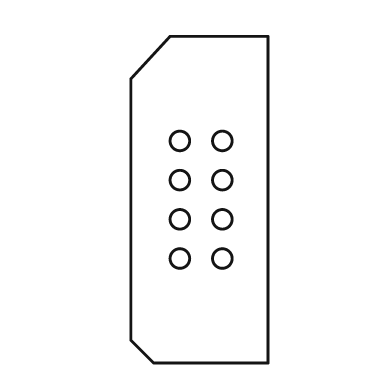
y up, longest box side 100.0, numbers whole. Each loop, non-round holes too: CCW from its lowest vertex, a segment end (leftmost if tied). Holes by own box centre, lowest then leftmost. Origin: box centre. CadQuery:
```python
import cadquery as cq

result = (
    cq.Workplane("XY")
    .moveTo(-14.0, -50.0)
    .lineTo(21.0, -50.0)
    .lineTo(21.0, 50.0)
    .lineTo(-9.0, 50.0)
    .lineTo(-21.0, 37.0)
    .lineTo(-21.0, -43.0)
    .close()
    .moveTo(-6.0, -18.0)
    .circle(3.0)
    .moveTo(7.0, -18.0)
    .circle(3.0)
    .moveTo(-6.0, -6.0)
    .circle(3.0)
    .moveTo(7.0, -6.0)
    .circle(3.0)
    .moveTo(-6.0, 6.0)
    .circle(3.0)
    .moveTo(7.0, 6.0)
    .circle(3.0)
    .moveTo(-6.0, 18.0)
    .circle(3.0)
    .moveTo(7.0, 18.0)
    .circle(3.0)
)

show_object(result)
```